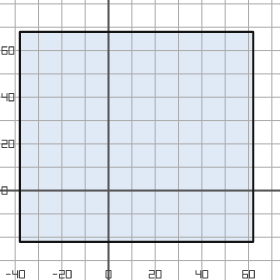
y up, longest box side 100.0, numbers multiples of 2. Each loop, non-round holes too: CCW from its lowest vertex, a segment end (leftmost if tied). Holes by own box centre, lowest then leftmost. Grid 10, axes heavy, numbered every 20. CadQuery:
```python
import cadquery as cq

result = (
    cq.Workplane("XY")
    .moveTo(-38.0, -22.0)
    .lineTo(62.0, -22.0)
    .lineTo(62.0, 68.0)
    .lineTo(-38.0, 68.0)
    .close()
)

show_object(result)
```